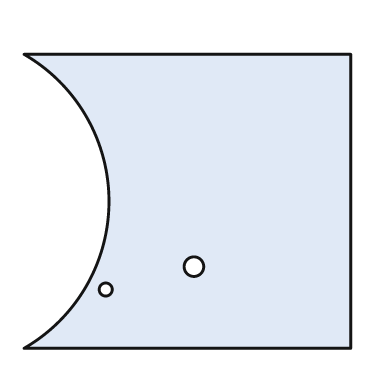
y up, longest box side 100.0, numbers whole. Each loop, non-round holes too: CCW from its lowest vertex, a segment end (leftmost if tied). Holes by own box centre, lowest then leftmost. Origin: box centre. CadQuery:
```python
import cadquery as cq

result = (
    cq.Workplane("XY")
    .moveTo(-50.0, -45.0)
    .lineTo(50.0, -45.0)
    .lineTo(50.0, 45.0)
    .lineTo(-50.0, 45.0)
    .threePointArc((-24.0, 0.0), (-50.0, -45.0))
    .close()
    .moveTo(-25.0, -27.0)
    .circle(2.0)
    .moveTo(2.0, -20.0)
    .circle(3.0)
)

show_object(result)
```